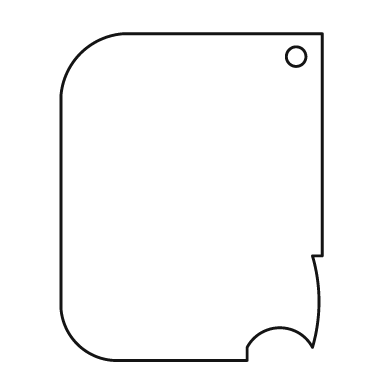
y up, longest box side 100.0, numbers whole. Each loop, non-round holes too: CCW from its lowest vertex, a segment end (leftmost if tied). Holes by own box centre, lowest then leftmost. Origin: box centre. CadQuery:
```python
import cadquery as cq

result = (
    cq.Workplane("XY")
    .moveTo(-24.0, -50.0)
    .lineTo(17.0, -50.0)
    .lineTo(17.0, -46.0)
    .threePointArc((27.0, -40.0), (37.0, -46.0))
    .threePointArc((39.0, -32.0), (37.0, -18.0))
    .lineTo(40.0, -18.0)
    .lineTo(40.0, 50.0)
    .lineTo(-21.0, 50.0)
    .threePointArc((-34.0, 44.0), (-40.0, 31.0))
    .lineTo(-40.0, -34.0)
    .threePointArc((-35.0, -45.0), (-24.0, -50.0))
    .close()
    .moveTo(32.0, 43.0)
    .circle(3.0)
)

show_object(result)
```